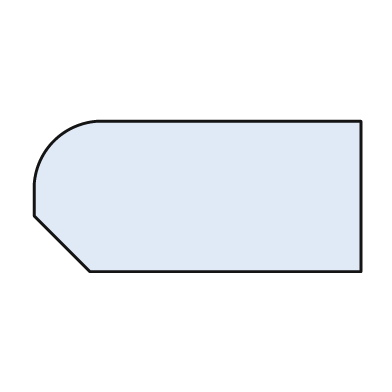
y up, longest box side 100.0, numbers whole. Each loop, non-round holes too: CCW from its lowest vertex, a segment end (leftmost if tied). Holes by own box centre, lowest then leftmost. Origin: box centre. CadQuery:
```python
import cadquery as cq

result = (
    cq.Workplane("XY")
    .moveTo(-33.0, -23.0)
    .lineTo(50.0, -23.0)
    .lineTo(50.0, 23.0)
    .lineTo(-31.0, 23.0)
    .threePointArc((-44.0, 17.0), (-50.0, 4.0))
    .lineTo(-50.0, -6.0)
    .close()
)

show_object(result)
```